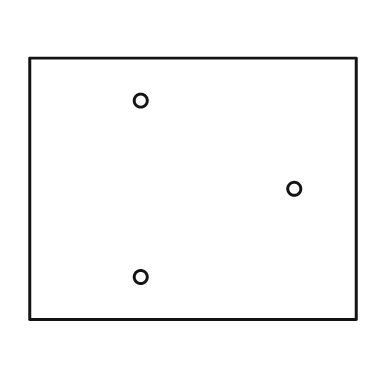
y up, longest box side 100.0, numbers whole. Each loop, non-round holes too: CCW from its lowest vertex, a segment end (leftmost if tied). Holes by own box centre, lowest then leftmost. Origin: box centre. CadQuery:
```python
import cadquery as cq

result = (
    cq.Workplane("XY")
    .moveTo(-50.0, -40.0)
    .lineTo(50.0, -40.0)
    .lineTo(50.0, 40.0)
    .lineTo(-50.0, 40.0)
    .close()
    .moveTo(-16.0, -27.0)
    .circle(2.0)
    .moveTo(31.0, 0.0)
    .circle(2.0)
    .moveTo(-16.0, 27.0)
    .circle(2.0)
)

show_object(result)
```